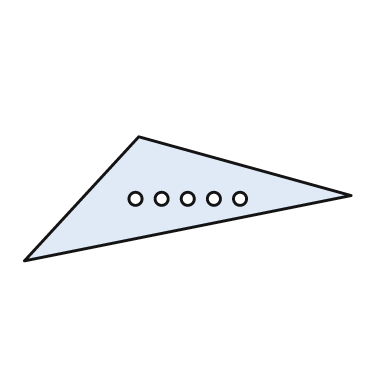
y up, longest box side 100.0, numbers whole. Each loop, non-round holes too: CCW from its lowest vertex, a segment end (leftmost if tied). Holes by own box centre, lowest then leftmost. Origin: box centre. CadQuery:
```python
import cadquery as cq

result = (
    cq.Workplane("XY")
    .moveTo(-50.0, -19.0)
    .lineTo(50.0, 1.0)
    .lineTo(-15.0, 19.0)
    .close()
    .moveTo(-16.0, 0.0)
    .circle(2.0)
    .moveTo(-8.0, 0.0)
    .circle(2.0)
    .moveTo(0.0, 0.0)
    .circle(2.0)
    .moveTo(8.0, 0.0)
    .circle(2.0)
    .moveTo(16.0, 0.0)
    .circle(2.0)
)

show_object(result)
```